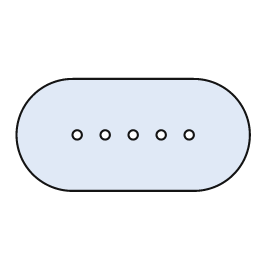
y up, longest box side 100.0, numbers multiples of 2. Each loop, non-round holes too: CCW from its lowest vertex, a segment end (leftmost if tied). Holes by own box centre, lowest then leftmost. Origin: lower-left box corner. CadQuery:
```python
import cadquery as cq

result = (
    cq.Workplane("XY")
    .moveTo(24.0, 0.0)
    .lineTo(76.0, 0.0)
    .threePointArc((100.0, 24.0), (76.0, 48.0))
    .lineTo(24.0, 48.0)
    .threePointArc((0.0, 24.0), (24.0, 0.0))
    .close()
    .moveTo(26.0, 24.0)
    .circle(2.0)
    .moveTo(38.0, 24.0)
    .circle(2.0)
    .moveTo(50.0, 24.0)
    .circle(2.0)
    .moveTo(62.0, 24.0)
    .circle(2.0)
    .moveTo(74.0, 24.0)
    .circle(2.0)
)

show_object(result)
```